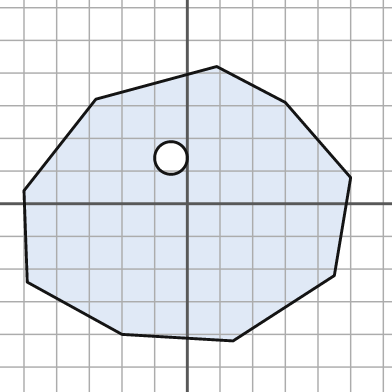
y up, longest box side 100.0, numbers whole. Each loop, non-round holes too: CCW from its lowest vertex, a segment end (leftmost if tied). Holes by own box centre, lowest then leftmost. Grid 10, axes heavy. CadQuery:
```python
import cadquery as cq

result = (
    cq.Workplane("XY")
    .moveTo(14.0, -42.0)
    .lineTo(45.0, -22.0)
    .lineTo(50.0, 8.0)
    .lineTo(30.0, 31.0)
    .lineTo(9.0, 42.0)
    .lineTo(-28.0, 32.0)
    .lineTo(-50.0, 4.0)
    .lineTo(-49.0, -24.0)
    .lineTo(-20.0, -40.0)
    .close()
    .moveTo(-5.0, 14.0)
    .circle(5.0)
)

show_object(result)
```